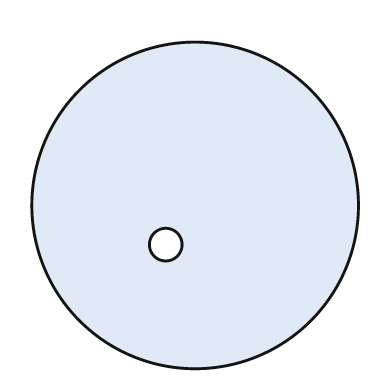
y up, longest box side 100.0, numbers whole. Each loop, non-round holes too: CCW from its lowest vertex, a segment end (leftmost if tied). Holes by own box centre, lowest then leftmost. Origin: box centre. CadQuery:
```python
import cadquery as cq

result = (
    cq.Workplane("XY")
    .moveTo(0.0, 0.0)
    .circle(50.0)
    .moveTo(-9.0, -12.0)
    .circle(5.0)
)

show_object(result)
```